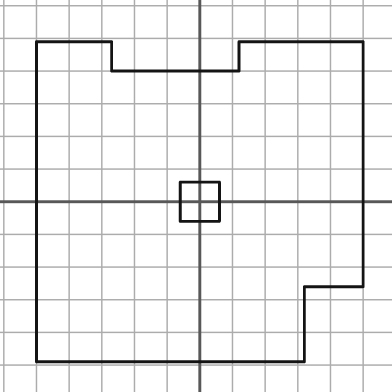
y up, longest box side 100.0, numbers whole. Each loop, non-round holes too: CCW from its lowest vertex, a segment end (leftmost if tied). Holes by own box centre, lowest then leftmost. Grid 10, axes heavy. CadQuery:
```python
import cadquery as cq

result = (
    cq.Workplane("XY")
    .moveTo(-50.0, -49.0)
    .lineTo(32.0, -49.0)
    .lineTo(32.0, -26.0)
    .lineTo(50.0, -26.0)
    .lineTo(50.0, 49.0)
    .lineTo(12.0, 49.0)
    .lineTo(12.0, 40.0)
    .lineTo(-27.0, 40.0)
    .lineTo(-27.0, 49.0)
    .lineTo(-50.0, 49.0)
    .close()
    .moveTo(-6.0, -6.0)
    .lineTo(6.0, -6.0)
    .lineTo(6.0, 6.0)
    .lineTo(-6.0, 6.0)
    .close()
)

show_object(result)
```